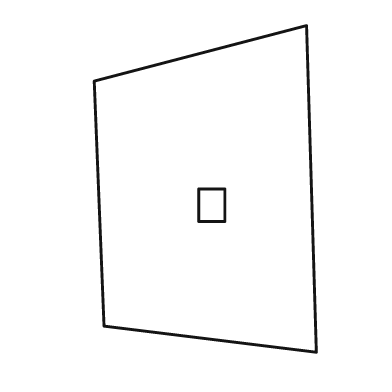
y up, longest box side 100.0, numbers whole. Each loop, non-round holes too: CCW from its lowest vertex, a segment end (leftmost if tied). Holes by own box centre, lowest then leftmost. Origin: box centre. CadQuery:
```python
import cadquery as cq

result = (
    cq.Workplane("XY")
    .moveTo(34.0, -50.0)
    .lineTo(31.0, 50.0)
    .lineTo(-34.0, 33.0)
    .lineTo(-31.0, -42.0)
    .close()
    .moveTo(-2.0, -10.0)
    .lineTo(6.0, -10.0)
    .lineTo(6.0, 0.0)
    .lineTo(-2.0, 0.0)
    .close()
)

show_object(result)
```